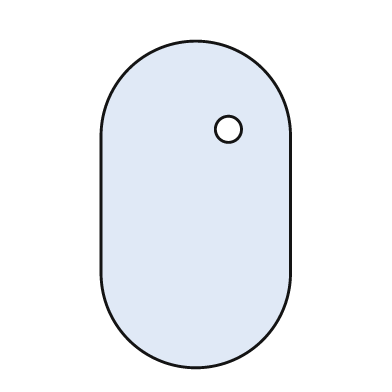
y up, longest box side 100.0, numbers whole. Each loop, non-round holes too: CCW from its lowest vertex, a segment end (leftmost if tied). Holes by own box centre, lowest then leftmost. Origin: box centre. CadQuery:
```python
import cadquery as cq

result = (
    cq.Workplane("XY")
    .moveTo(-29.0, -21.0)
    .threePointArc((0.0, -50.0), (29.0, -21.0))
    .lineTo(29.0, 21.0)
    .threePointArc((0.0, 50.0), (-29.0, 21.0))
    .close()
    .moveTo(10.0, 23.0)
    .circle(4.0)
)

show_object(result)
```